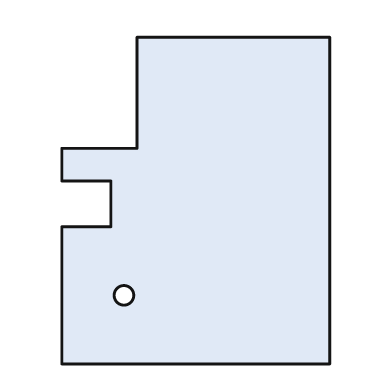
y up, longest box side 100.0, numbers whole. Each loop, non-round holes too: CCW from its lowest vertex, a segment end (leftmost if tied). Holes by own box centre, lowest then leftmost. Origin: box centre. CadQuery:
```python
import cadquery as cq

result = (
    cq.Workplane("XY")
    .moveTo(-41.0, -50.0)
    .lineTo(41.0, -50.0)
    .lineTo(41.0, 50.0)
    .lineTo(-18.0, 50.0)
    .lineTo(-18.0, 16.0)
    .lineTo(-41.0, 16.0)
    .lineTo(-41.0, 6.0)
    .lineTo(-26.0, 6.0)
    .lineTo(-26.0, -8.0)
    .lineTo(-41.0, -8.0)
    .close()
    .moveTo(-22.0, -29.0)
    .circle(3.0)
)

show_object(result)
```